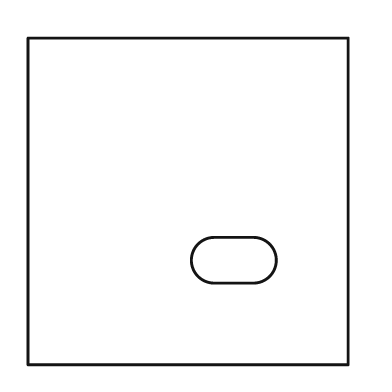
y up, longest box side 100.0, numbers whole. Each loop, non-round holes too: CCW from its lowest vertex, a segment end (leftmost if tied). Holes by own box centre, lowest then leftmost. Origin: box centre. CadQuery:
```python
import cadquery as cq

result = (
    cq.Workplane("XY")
    .moveTo(-49.0, -50.0)
    .lineTo(49.0, -50.0)
    .lineTo(49.0, 50.0)
    .lineTo(-49.0, 50.0)
    .close()
    .moveTo(8.0, -25.0)
    .lineTo(20.0, -25.0)
    .threePointArc((27.0, -18.0), (20.0, -11.0))
    .lineTo(8.0, -11.0)
    .threePointArc((1.0, -18.0), (8.0, -25.0))
    .close()
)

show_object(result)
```